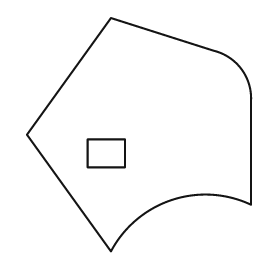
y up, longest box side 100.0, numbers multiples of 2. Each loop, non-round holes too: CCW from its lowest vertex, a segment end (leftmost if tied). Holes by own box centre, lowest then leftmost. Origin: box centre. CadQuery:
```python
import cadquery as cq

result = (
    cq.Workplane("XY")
    .moveTo(-12.0, -50.0)
    .threePointArc((14.0, -28.0), (48.0, -30.0))
    .lineTo(48.0, 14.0)
    .threePointArc((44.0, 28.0), (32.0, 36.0))
    .lineTo(-12.0, 50.0)
    .lineTo(-48.0, 0.0)
    .close()
    .moveTo(-22.0, -14.0)
    .lineTo(-6.0, -14.0)
    .lineTo(-6.0, -2.0)
    .lineTo(-22.0, -2.0)
    .close()
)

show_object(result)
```